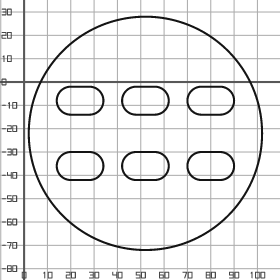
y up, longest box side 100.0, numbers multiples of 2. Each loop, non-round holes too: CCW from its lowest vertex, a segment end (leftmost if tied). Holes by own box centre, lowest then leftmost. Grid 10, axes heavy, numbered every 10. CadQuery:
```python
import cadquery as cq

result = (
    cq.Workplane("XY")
    .moveTo(52.0, -22.0)
    .circle(50.0)
    .moveTo(20.0, -42.0)
    .lineTo(28.0, -42.0)
    .threePointArc((34.0, -36.0), (28.0, -30.0))
    .lineTo(20.0, -30.0)
    .threePointArc((14.0, -36.0), (20.0, -42.0))
    .close()
    .moveTo(48.0, -42.0)
    .lineTo(56.0, -42.0)
    .threePointArc((62.0, -36.0), (56.0, -30.0))
    .lineTo(48.0, -30.0)
    .threePointArc((42.0, -36.0), (48.0, -42.0))
    .close()
    .moveTo(76.0, -42.0)
    .lineTo(84.0, -42.0)
    .threePointArc((90.0, -36.0), (84.0, -30.0))
    .lineTo(76.0, -30.0)
    .threePointArc((70.0, -36.0), (76.0, -42.0))
    .close()
    .moveTo(20.0, -14.0)
    .lineTo(28.0, -14.0)
    .threePointArc((34.0, -8.0), (28.0, -2.0))
    .lineTo(20.0, -2.0)
    .threePointArc((14.0, -8.0), (20.0, -14.0))
    .close()
    .moveTo(48.0, -14.0)
    .lineTo(56.0, -14.0)
    .threePointArc((62.0, -8.0), (56.0, -2.0))
    .lineTo(48.0, -2.0)
    .threePointArc((42.0, -8.0), (48.0, -14.0))
    .close()
    .moveTo(76.0, -14.0)
    .lineTo(84.0, -14.0)
    .threePointArc((90.0, -8.0), (84.0, -2.0))
    .lineTo(76.0, -2.0)
    .threePointArc((70.0, -8.0), (76.0, -14.0))
    .close()
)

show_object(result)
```